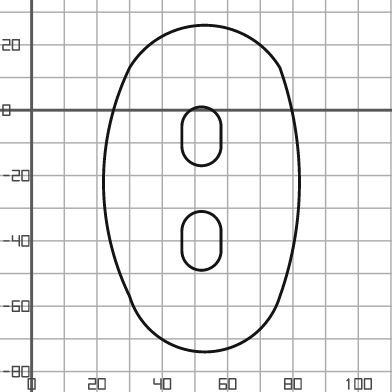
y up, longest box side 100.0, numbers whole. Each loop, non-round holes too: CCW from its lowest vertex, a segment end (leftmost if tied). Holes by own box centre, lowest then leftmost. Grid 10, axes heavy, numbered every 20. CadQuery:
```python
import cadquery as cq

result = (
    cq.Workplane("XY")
    .moveTo(30.0, -57.0)
    .threePointArc((53.0, -74.0), (76.0, -57.0))
    .threePointArc((82.0, -22.0), (76.0, 13.0))
    .threePointArc((53.0, 26.0), (30.0, 13.0))
    .threePointArc((22.0, -22.0), (30.0, -57.0))
    .close()
    .moveTo(46.0, -43.0)
    .threePointArc((52.0, -49.0), (58.0, -43.0))
    .lineTo(58.0, -37.0)
    .threePointArc((52.0, -31.0), (46.0, -37.0))
    .close()
    .moveTo(46.0, -11.0)
    .threePointArc((52.0, -17.0), (58.0, -11.0))
    .lineTo(58.0, -5.0)
    .threePointArc((52.0, 1.0), (46.0, -5.0))
    .close()
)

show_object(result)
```